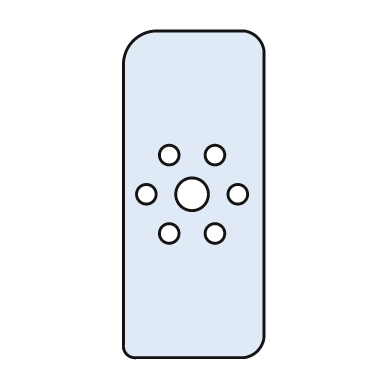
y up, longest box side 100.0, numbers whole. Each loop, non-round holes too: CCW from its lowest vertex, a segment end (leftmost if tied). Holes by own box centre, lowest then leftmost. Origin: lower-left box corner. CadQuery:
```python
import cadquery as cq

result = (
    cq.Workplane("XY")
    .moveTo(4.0, 0.0)
    .lineTo(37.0, 0.0)
    .threePointArc((41.0, 2.0), (43.0, 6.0))
    .lineTo(43.0, 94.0)
    .threePointArc((41.0, 98.0), (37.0, 100.0))
    .lineTo(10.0, 100.0)
    .threePointArc((3.0, 97.0), (0.0, 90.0))
    .lineTo(0.0, 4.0)
    .threePointArc((1.0, 1.0), (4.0, 0.0))
    .close()
    .moveTo(14.0, 38.0)
    .circle(3.0)
    .moveTo(28.0, 38.0)
    .circle(3.0)
    .moveTo(7.0, 50.0)
    .circle(3.0)
    .moveTo(21.0, 50.0)
    .circle(5.0)
    .moveTo(35.0, 50.0)
    .circle(3.0)
    .moveTo(14.0, 62.0)
    .circle(3.0)
    .moveTo(28.0, 62.0)
    .circle(3.0)
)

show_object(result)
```